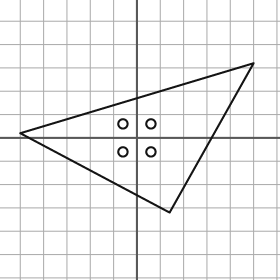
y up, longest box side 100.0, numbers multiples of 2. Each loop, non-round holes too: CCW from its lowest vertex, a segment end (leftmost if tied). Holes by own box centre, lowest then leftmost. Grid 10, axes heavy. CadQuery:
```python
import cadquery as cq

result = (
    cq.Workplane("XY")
    .moveTo(14.0, -32.0)
    .lineTo(50.0, 32.0)
    .lineTo(-50.0, 2.0)
    .close()
    .moveTo(-6.0, -6.0)
    .circle(2.0)
    .moveTo(6.0, -6.0)
    .circle(2.0)
    .moveTo(-6.0, 6.0)
    .circle(2.0)
    .moveTo(6.0, 6.0)
    .circle(2.0)
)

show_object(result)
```